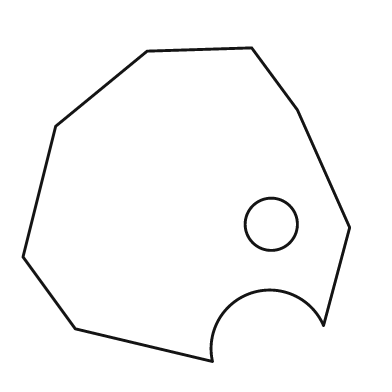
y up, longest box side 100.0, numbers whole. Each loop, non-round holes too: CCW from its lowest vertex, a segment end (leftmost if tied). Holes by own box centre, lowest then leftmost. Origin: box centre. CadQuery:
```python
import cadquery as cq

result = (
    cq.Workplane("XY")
    .moveTo(8.0, -48.0)
    .threePointArc((20.0, -27.0), (42.0, -37.0))
    .lineTo(50.0, -7.0)
    .lineTo(34.0, 29.0)
    .lineTo(20.0, 48.0)
    .lineTo(-12.0, 47.0)
    .lineTo(-40.0, 24.0)
    .lineTo(-50.0, -16.0)
    .lineTo(-34.0, -38.0)
    .close()
    .moveTo(26.0, -6.0)
    .circle(8.0)
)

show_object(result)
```